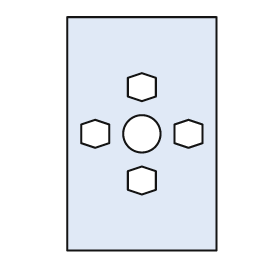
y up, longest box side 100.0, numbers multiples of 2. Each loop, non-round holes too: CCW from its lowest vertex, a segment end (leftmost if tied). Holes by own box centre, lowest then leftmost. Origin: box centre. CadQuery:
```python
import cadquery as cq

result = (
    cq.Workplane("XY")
    .moveTo(-32.0, -50.0)
    .lineTo(32.0, -50.0)
    .lineTo(32.0, 50.0)
    .lineTo(-32.0, 50.0)
    .close()
    .moveTo(0.0, -26.0)
    .lineTo(6.0, -24.0)
    .lineTo(6.0, -16.0)
    .lineTo(0.0, -14.0)
    .lineTo(-6.0, -16.0)
    .lineTo(-6.0, -24.0)
    .close()
    .moveTo(-20.0, -6.0)
    .lineTo(-14.0, -4.0)
    .lineTo(-14.0, 4.0)
    .lineTo(-20.0, 6.0)
    .lineTo(-26.0, 4.0)
    .lineTo(-26.0, -4.0)
    .close()
    .moveTo(0.0, 0.0)
    .circle(8.0)
    .moveTo(20.0, -6.0)
    .lineTo(26.0, -4.0)
    .lineTo(26.0, 4.0)
    .lineTo(20.0, 6.0)
    .lineTo(14.0, 4.0)
    .lineTo(14.0, -4.0)
    .close()
    .moveTo(0.0, 14.0)
    .lineTo(6.0, 16.0)
    .lineTo(6.0, 24.0)
    .lineTo(0.0, 26.0)
    .lineTo(-6.0, 24.0)
    .lineTo(-6.0, 16.0)
    .close()
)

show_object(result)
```